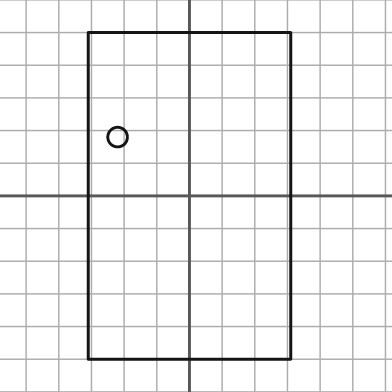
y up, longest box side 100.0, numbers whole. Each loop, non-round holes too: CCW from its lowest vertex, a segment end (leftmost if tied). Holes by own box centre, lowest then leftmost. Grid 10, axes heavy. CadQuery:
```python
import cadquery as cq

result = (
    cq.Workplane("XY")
    .moveTo(-31.0, -50.0)
    .lineTo(31.0, -50.0)
    .lineTo(31.0, 50.0)
    .lineTo(-31.0, 50.0)
    .close()
    .moveTo(-22.0, 18.0)
    .circle(3.0)
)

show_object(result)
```